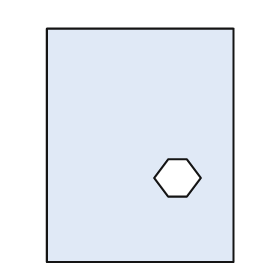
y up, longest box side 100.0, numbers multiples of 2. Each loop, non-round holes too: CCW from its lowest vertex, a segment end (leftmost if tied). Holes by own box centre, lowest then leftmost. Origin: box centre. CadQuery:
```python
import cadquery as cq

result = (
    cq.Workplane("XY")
    .moveTo(-40.0, -50.0)
    .lineTo(40.0, -50.0)
    .lineTo(40.0, 50.0)
    .lineTo(-40.0, 50.0)
    .close()
    .moveTo(12.0, -22.0)
    .lineTo(20.0, -22.0)
    .lineTo(26.0, -14.0)
    .lineTo(20.0, -6.0)
    .lineTo(12.0, -6.0)
    .lineTo(6.0, -14.0)
    .close()
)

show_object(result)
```